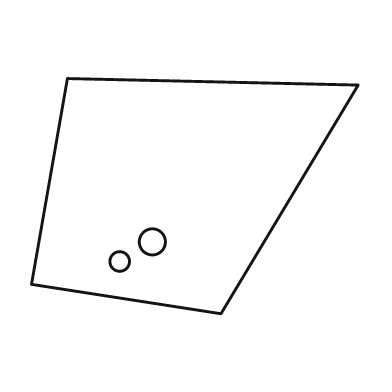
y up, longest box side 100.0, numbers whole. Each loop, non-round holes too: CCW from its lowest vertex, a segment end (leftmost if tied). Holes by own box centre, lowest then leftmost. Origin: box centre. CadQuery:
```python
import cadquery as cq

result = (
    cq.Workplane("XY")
    .moveTo(8.0, -36.0)
    .lineTo(50.0, 34.0)
    .lineTo(-39.0, 36.0)
    .lineTo(-50.0, -27.0)
    .close()
    .moveTo(-23.0, -20.0)
    .circle(3.0)
    .moveTo(-13.0, -14.0)
    .circle(4.0)
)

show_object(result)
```